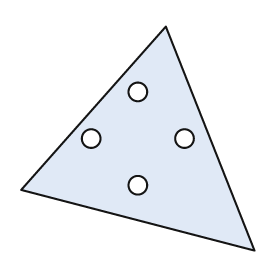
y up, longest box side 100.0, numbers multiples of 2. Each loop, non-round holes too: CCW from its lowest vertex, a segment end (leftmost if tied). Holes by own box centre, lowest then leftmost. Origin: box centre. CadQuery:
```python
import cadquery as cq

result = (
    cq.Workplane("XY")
    .moveTo(50.0, -48.0)
    .lineTo(12.0, 48.0)
    .lineTo(-50.0, -22.0)
    .close()
    .moveTo(0.0, -20.0)
    .circle(4.0)
    .moveTo(-20.0, 0.0)
    .circle(4.0)
    .moveTo(20.0, 0.0)
    .circle(4.0)
    .moveTo(0.0, 20.0)
    .circle(4.0)
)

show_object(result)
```